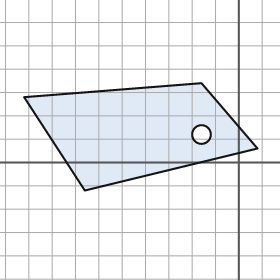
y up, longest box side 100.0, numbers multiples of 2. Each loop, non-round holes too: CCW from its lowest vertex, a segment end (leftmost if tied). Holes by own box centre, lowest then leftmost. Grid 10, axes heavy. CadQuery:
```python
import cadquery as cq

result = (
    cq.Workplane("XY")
    .moveTo(-66.0, -12.0)
    .lineTo(8.0, 6.0)
    .lineTo(-16.0, 34.0)
    .lineTo(-92.0, 28.0)
    .close()
    .moveTo(-16.0, 12.0)
    .circle(4.0)
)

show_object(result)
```